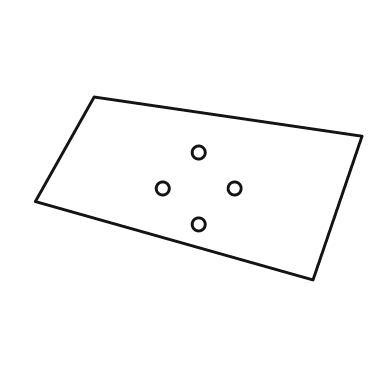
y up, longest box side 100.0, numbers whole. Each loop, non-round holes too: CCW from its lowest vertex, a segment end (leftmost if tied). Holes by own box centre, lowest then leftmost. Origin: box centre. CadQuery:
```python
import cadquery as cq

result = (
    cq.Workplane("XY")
    .moveTo(35.0, -28.0)
    .lineTo(50.0, 16.0)
    .lineTo(-32.0, 28.0)
    .lineTo(-50.0, -4.0)
    .close()
    .moveTo(0.0, -11.0)
    .circle(2.0)
    .moveTo(-11.0, 0.0)
    .circle(2.0)
    .moveTo(11.0, 0.0)
    .circle(2.0)
    .moveTo(0.0, 11.0)
    .circle(2.0)
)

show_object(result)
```